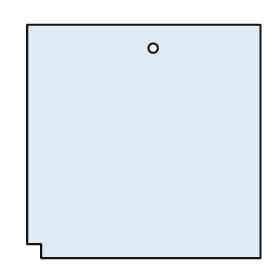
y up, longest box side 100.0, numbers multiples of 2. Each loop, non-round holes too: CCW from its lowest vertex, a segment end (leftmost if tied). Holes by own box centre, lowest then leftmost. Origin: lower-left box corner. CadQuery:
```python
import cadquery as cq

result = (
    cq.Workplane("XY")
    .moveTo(6.0, 0.0)
    .lineTo(100.0, 0.0)
    .lineTo(100.0, 100.0)
    .lineTo(0.0, 100.0)
    .lineTo(0.0, 6.0)
    .lineTo(6.0, 6.0)
    .close()
    .moveTo(54.0, 90.0)
    .circle(2.0)
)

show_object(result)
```